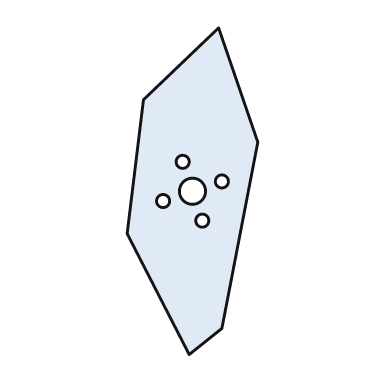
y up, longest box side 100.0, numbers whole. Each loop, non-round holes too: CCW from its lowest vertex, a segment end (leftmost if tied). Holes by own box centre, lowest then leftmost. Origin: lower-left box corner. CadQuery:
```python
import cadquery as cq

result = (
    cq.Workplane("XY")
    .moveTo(19.0, 0.0)
    .lineTo(29.0, 8.0)
    .lineTo(40.0, 65.0)
    .lineTo(28.0, 100.0)
    .lineTo(5.0, 78.0)
    .lineTo(0.0, 37.0)
    .close()
    .moveTo(23.0, 41.0)
    .circle(2.0)
    .moveTo(11.0, 47.0)
    .circle(2.0)
    .moveTo(20.0, 50.0)
    .circle(4.0)
    .moveTo(29.0, 53.0)
    .circle(2.0)
    .moveTo(17.0, 59.0)
    .circle(2.0)
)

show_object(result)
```